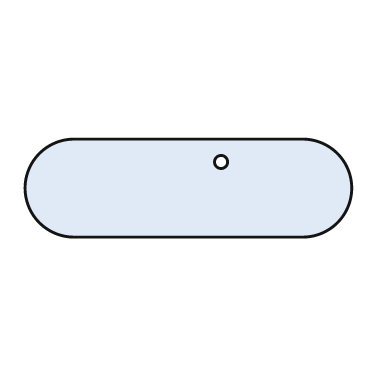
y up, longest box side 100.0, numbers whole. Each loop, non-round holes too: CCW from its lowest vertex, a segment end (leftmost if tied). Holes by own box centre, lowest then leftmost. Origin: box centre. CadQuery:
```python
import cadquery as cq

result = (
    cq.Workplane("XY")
    .moveTo(-35.0, -15.0)
    .lineTo(35.0, -15.0)
    .threePointArc((50.0, 0.0), (35.0, 15.0))
    .lineTo(-35.0, 15.0)
    .threePointArc((-50.0, 0.0), (-35.0, -15.0))
    .close()
    .moveTo(10.0, 8.0)
    .circle(2.0)
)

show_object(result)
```